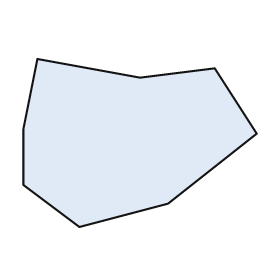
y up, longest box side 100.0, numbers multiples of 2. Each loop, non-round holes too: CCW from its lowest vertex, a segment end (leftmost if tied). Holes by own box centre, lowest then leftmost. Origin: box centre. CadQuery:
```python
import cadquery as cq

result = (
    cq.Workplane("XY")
    .moveTo(-26.0, -36.0)
    .lineTo(12.0, -26.0)
    .lineTo(50.0, 4.0)
    .lineTo(32.0, 32.0)
    .lineTo(0.0, 28.0)
    .lineTo(-44.0, 36.0)
    .lineTo(-50.0, 6.0)
    .lineTo(-50.0, -18.0)
    .close()
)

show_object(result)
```